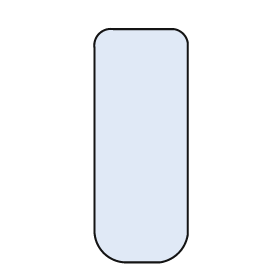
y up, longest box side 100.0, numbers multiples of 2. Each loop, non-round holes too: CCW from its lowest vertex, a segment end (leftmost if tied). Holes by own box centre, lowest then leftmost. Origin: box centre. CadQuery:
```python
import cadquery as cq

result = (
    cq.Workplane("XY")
    .moveTo(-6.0, -50.0)
    .lineTo(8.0, -50.0)
    .threePointArc((16.0, -46.0), (20.0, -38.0))
    .lineTo(20.0, 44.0)
    .threePointArc((18.0, 48.0), (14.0, 50.0))
    .lineTo(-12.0, 50.0)
    .threePointArc((-18.0, 48.0), (-20.0, 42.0))
    .lineTo(-20.0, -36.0)
    .threePointArc((-16.0, -46.0), (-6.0, -50.0))
    .close()
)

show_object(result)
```